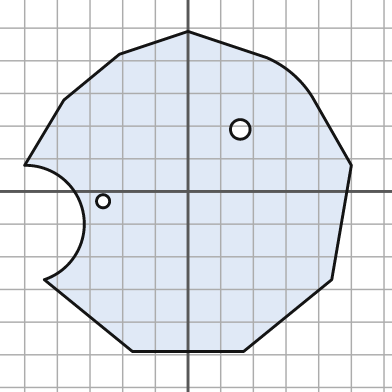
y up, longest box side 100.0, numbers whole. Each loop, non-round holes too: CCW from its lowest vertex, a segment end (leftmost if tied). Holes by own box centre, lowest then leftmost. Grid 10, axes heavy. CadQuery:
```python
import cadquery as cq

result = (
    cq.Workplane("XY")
    .moveTo(-17.0, -49.0)
    .lineTo(17.0, -49.0)
    .lineTo(44.0, -27.0)
    .lineTo(50.0, 8.0)
    .lineTo(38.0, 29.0)
    .threePointArc((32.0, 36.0), (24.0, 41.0))
    .lineTo(0.0, 49.0)
    .lineTo(-21.0, 42.0)
    .lineTo(-38.0, 28.0)
    .lineTo(-50.0, 8.0)
    .threePointArc((-32.0, -7.0), (-44.0, -27.0))
    .close()
    .moveTo(-26.0, -3.0)
    .circle(2.0)
    .moveTo(16.0, 19.0)
    .circle(3.0)
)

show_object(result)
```